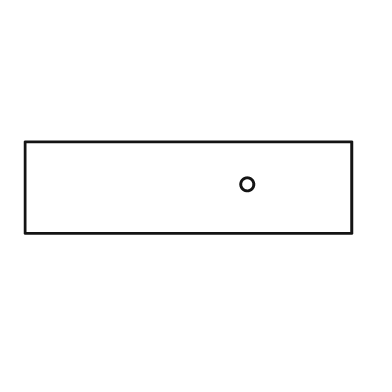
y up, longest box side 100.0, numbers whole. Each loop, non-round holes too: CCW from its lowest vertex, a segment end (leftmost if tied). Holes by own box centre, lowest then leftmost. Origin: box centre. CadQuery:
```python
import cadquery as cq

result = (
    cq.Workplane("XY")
    .moveTo(-50.0, -14.0)
    .lineTo(50.0, -14.0)
    .lineTo(50.0, 14.0)
    .lineTo(-50.0, 14.0)
    .close()
    .moveTo(18.0, 1.0)
    .circle(2.0)
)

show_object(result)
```